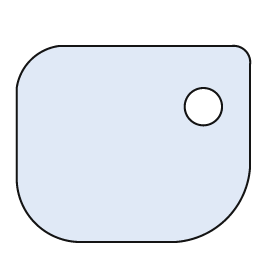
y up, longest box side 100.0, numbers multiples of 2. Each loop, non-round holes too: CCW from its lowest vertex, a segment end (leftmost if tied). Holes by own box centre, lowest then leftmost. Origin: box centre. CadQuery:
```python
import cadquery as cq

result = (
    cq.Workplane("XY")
    .moveTo(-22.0, -42.0)
    .lineTo(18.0, -42.0)
    .threePointArc((40.0, -32.0), (50.0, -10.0))
    .lineTo(50.0, 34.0)
    .threePointArc((48.0, 40.0), (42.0, 42.0))
    .lineTo(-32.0, 42.0)
    .threePointArc((-44.0, 36.0), (-50.0, 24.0))
    .lineTo(-50.0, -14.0)
    .threePointArc((-42.0, -34.0), (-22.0, -42.0))
    .close()
    .moveTo(30.0, 16.0)
    .circle(8.0)
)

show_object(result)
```